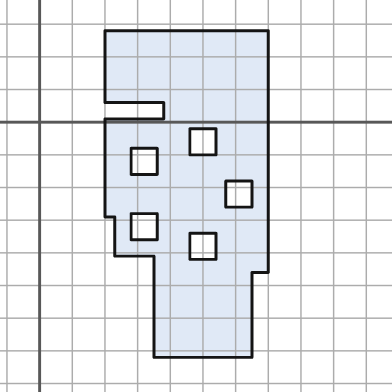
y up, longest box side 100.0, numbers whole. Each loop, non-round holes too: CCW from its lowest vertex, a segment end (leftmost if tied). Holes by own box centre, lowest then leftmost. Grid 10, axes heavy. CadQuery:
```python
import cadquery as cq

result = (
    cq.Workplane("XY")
    .moveTo(35.0, -72.0)
    .lineTo(65.0, -72.0)
    .lineTo(65.0, -46.0)
    .lineTo(70.0, -46.0)
    .lineTo(70.0, 28.0)
    .lineTo(20.0, 28.0)
    .lineTo(20.0, 6.0)
    .lineTo(38.0, 6.0)
    .lineTo(38.0, 1.0)
    .lineTo(20.0, 1.0)
    .lineTo(20.0, -29.0)
    .lineTo(23.0, -29.0)
    .lineTo(23.0, -41.0)
    .lineTo(35.0, -41.0)
    .close()
    .moveTo(46.0, -42.0)
    .lineTo(54.0, -42.0)
    .lineTo(54.0, -34.0)
    .lineTo(46.0, -34.0)
    .close()
    .moveTo(28.0, -36.0)
    .lineTo(36.0, -36.0)
    .lineTo(36.0, -28.0)
    .lineTo(28.0, -28.0)
    .close()
    .moveTo(57.0, -26.0)
    .lineTo(65.0, -26.0)
    .lineTo(65.0, -18.0)
    .lineTo(57.0, -18.0)
    .close()
    .moveTo(28.0, -16.0)
    .lineTo(36.0, -16.0)
    .lineTo(36.0, -8.0)
    .lineTo(28.0, -8.0)
    .close()
    .moveTo(46.0, -10.0)
    .lineTo(54.0, -10.0)
    .lineTo(54.0, -2.0)
    .lineTo(46.0, -2.0)
    .close()
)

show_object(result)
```